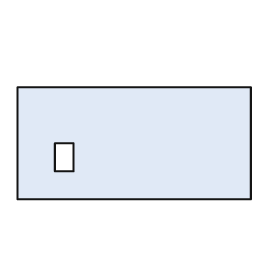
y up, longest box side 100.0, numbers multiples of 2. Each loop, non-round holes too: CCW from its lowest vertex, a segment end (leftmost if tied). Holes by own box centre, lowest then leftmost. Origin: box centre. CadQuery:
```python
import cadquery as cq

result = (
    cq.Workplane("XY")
    .moveTo(-50.0, -24.0)
    .lineTo(50.0, -24.0)
    .lineTo(50.0, 24.0)
    .lineTo(-50.0, 24.0)
    .close()
    .moveTo(-34.0, -12.0)
    .lineTo(-26.0, -12.0)
    .lineTo(-26.0, 0.0)
    .lineTo(-34.0, 0.0)
    .close()
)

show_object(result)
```